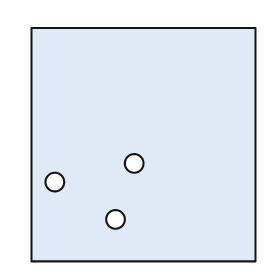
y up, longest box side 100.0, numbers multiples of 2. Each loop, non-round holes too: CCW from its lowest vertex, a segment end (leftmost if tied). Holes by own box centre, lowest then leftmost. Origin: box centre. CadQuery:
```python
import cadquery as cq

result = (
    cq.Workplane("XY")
    .moveTo(-48.0, -50.0)
    .lineTo(48.0, -50.0)
    .lineTo(48.0, 50.0)
    .lineTo(-48.0, 50.0)
    .close()
    .moveTo(-12.0, -32.0)
    .circle(4.0)
    .moveTo(-38.0, -16.0)
    .circle(4.0)
    .moveTo(-4.0, -8.0)
    .circle(4.0)
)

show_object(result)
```